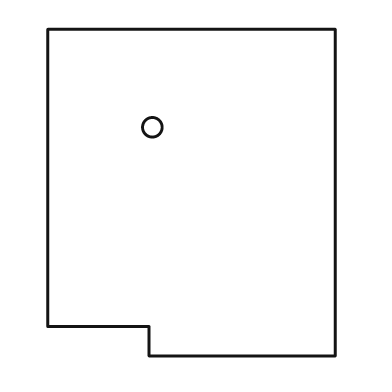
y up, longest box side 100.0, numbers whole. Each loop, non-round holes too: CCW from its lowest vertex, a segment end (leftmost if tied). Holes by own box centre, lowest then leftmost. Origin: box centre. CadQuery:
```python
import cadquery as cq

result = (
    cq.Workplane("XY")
    .moveTo(-13.0, -50.0)
    .lineTo(44.0, -50.0)
    .lineTo(44.0, 50.0)
    .lineTo(-44.0, 50.0)
    .lineTo(-44.0, -41.0)
    .lineTo(-13.0, -41.0)
    .close()
    .moveTo(-12.0, 20.0)
    .circle(3.0)
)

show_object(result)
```